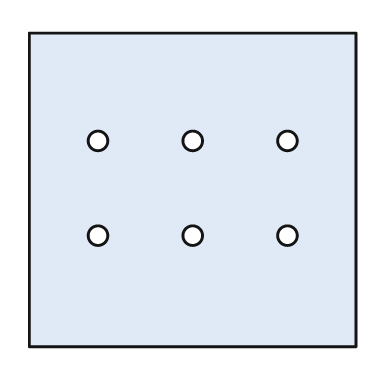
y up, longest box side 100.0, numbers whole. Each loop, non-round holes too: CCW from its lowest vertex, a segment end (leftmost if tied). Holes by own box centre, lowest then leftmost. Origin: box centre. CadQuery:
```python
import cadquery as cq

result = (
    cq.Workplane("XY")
    .moveTo(-50.0, -48.0)
    .lineTo(50.0, -48.0)
    .lineTo(50.0, 48.0)
    .lineTo(-50.0, 48.0)
    .close()
    .moveTo(-29.0, -14.0)
    .circle(3.0)
    .moveTo(0.0, -14.0)
    .circle(3.0)
    .moveTo(29.0, -14.0)
    .circle(3.0)
    .moveTo(-29.0, 15.0)
    .circle(3.0)
    .moveTo(0.0, 15.0)
    .circle(3.0)
    .moveTo(29.0, 15.0)
    .circle(3.0)
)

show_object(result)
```